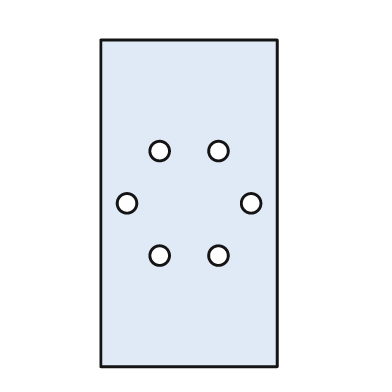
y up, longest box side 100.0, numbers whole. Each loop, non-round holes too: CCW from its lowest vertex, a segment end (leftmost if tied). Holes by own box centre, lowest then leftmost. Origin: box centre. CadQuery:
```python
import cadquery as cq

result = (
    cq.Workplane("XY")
    .moveTo(-27.0, -50.0)
    .lineTo(27.0, -50.0)
    .lineTo(27.0, 50.0)
    .lineTo(-27.0, 50.0)
    .close()
    .moveTo(-9.0, -16.0)
    .circle(3.0)
    .moveTo(9.0, -16.0)
    .circle(3.0)
    .moveTo(-19.0, 0.0)
    .circle(3.0)
    .moveTo(19.0, 0.0)
    .circle(3.0)
    .moveTo(-9.0, 16.0)
    .circle(3.0)
    .moveTo(9.0, 16.0)
    .circle(3.0)
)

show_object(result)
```